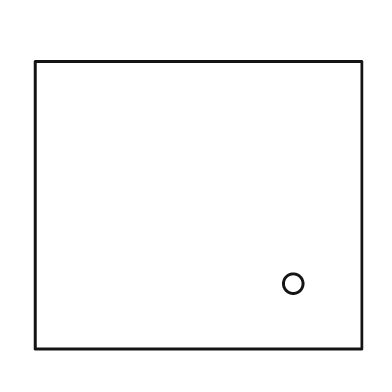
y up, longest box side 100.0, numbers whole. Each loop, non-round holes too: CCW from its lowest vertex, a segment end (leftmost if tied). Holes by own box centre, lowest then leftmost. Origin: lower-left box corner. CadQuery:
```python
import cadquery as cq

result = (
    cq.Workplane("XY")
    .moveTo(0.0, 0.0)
    .lineTo(100.0, 0.0)
    .lineTo(100.0, 88.0)
    .lineTo(0.0, 88.0)
    .close()
    .moveTo(79.0, 20.0)
    .circle(3.0)
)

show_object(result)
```